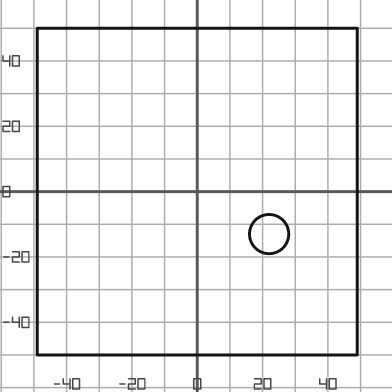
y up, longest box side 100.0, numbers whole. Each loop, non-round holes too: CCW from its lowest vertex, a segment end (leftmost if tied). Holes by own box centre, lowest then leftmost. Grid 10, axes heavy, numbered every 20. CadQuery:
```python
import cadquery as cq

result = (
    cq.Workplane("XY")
    .moveTo(-49.0, -50.0)
    .lineTo(49.0, -50.0)
    .lineTo(49.0, 50.0)
    .lineTo(-49.0, 50.0)
    .close()
    .moveTo(22.0, -13.0)
    .circle(6.0)
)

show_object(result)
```